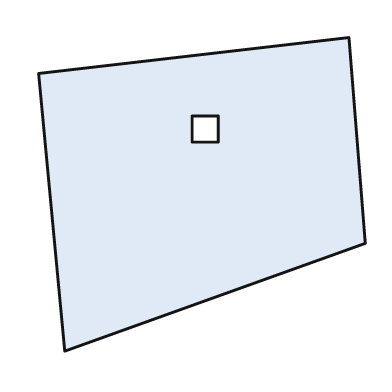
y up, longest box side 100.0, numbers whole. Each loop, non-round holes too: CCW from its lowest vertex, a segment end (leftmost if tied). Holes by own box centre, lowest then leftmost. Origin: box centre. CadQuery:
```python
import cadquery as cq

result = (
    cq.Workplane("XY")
    .moveTo(-42.0, -48.0)
    .lineTo(50.0, -15.0)
    .lineTo(45.0, 48.0)
    .lineTo(-50.0, 37.0)
    .close()
    .moveTo(-3.0, 16.0)
    .lineTo(5.0, 16.0)
    .lineTo(5.0, 24.0)
    .lineTo(-3.0, 24.0)
    .close()
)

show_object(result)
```